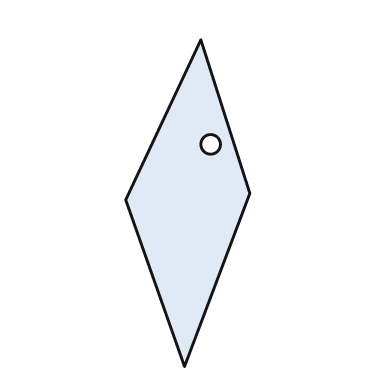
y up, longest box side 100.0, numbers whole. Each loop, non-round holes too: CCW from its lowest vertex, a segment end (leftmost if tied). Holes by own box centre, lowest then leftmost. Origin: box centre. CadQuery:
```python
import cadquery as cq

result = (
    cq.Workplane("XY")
    .moveTo(-1.0, -50.0)
    .lineTo(19.0, 3.0)
    .lineTo(4.0, 50.0)
    .lineTo(-19.0, 1.0)
    .close()
    .moveTo(7.0, 18.0)
    .circle(3.0)
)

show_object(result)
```